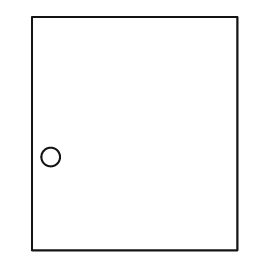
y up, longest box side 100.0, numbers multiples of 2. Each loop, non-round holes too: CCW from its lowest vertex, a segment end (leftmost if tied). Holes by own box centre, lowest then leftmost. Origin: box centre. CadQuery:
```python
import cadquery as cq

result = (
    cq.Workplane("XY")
    .moveTo(-44.0, -50.0)
    .lineTo(44.0, -50.0)
    .lineTo(44.0, 50.0)
    .lineTo(-44.0, 50.0)
    .close()
    .moveTo(-36.0, -10.0)
    .circle(4.0)
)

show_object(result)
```